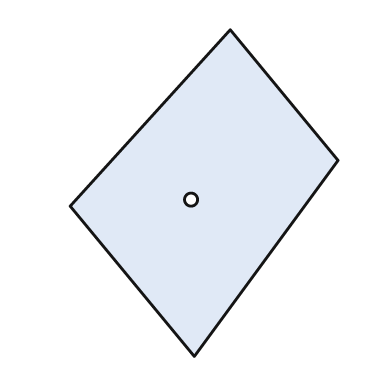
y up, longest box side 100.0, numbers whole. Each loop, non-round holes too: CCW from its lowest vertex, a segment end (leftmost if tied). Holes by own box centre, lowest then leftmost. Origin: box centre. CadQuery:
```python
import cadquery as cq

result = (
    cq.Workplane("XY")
    .moveTo(-3.0, -50.0)
    .lineTo(41.0, 10.0)
    .lineTo(8.0, 50.0)
    .lineTo(-41.0, -4.0)
    .close()
    .moveTo(-4.0, -2.0)
    .circle(2.0)
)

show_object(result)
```